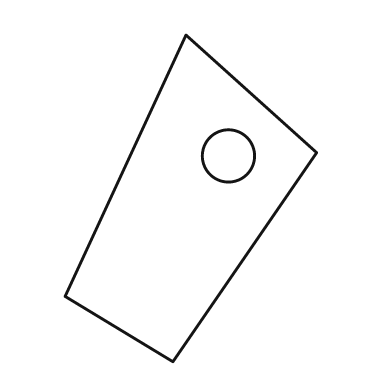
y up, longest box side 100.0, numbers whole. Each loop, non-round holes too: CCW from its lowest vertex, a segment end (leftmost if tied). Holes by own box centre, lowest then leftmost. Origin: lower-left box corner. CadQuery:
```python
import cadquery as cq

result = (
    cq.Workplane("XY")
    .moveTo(33.0, 0.0)
    .lineTo(77.0, 64.0)
    .lineTo(37.0, 100.0)
    .lineTo(0.0, 20.0)
    .close()
    .moveTo(50.0, 63.0)
    .circle(8.0)
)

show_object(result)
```